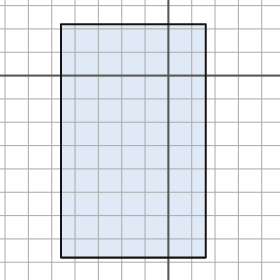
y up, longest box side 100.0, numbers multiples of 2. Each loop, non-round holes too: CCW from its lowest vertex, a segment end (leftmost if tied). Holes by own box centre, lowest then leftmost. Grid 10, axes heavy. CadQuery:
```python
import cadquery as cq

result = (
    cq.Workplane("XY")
    .moveTo(-46.0, -78.0)
    .lineTo(16.0, -78.0)
    .lineTo(16.0, 22.0)
    .lineTo(-46.0, 22.0)
    .close()
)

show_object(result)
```